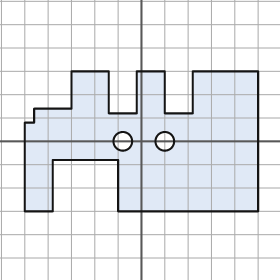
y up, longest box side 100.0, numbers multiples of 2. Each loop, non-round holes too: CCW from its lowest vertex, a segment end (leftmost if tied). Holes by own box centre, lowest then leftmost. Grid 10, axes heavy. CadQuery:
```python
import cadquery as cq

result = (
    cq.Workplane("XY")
    .moveTo(-50.0, -30.0)
    .lineTo(-38.0, -30.0)
    .lineTo(-38.0, -8.0)
    .lineTo(-10.0, -8.0)
    .lineTo(-10.0, -30.0)
    .lineTo(50.0, -30.0)
    .lineTo(50.0, 30.0)
    .lineTo(22.0, 30.0)
    .lineTo(22.0, 12.0)
    .lineTo(10.0, 12.0)
    .lineTo(10.0, 30.0)
    .lineTo(-2.0, 30.0)
    .lineTo(-2.0, 12.0)
    .lineTo(-14.0, 12.0)
    .lineTo(-14.0, 30.0)
    .lineTo(-30.0, 30.0)
    .lineTo(-30.0, 14.0)
    .lineTo(-46.0, 14.0)
    .lineTo(-46.0, 8.0)
    .lineTo(-50.0, 8.0)
    .close()
    .moveTo(-8.0, 0.0)
    .circle(4.0)
    .moveTo(10.0, 0.0)
    .circle(4.0)
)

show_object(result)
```